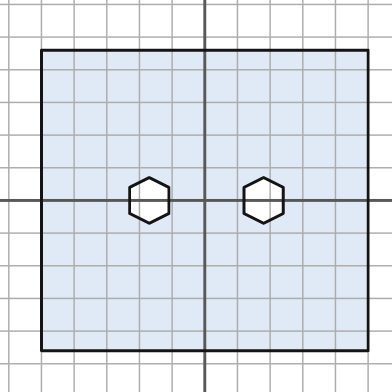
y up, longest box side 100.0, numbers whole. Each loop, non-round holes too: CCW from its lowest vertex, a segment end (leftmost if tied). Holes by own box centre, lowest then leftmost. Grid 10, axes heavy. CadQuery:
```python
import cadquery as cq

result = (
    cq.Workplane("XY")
    .moveTo(-50.0, -46.0)
    .lineTo(50.0, -46.0)
    .lineTo(50.0, 46.0)
    .lineTo(-50.0, 46.0)
    .close()
    .moveTo(-17.0, -7.0)
    .lineTo(-11.0, -4.0)
    .lineTo(-11.0, 4.0)
    .lineTo(-17.0, 7.0)
    .lineTo(-23.0, 4.0)
    .lineTo(-23.0, -4.0)
    .close()
    .moveTo(18.0, -7.0)
    .lineTo(24.0, -4.0)
    .lineTo(24.0, 4.0)
    .lineTo(18.0, 7.0)
    .lineTo(12.0, 4.0)
    .lineTo(12.0, -4.0)
    .close()
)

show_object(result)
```